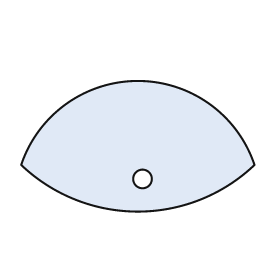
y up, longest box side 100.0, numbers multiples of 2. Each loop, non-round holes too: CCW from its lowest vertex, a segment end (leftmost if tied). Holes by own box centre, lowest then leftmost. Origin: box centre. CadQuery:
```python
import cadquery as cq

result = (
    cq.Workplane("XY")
    .moveTo(-50.0, -8.0)
    .threePointArc((0.0, -28.0), (50.0, -8.0))
    .threePointArc((0.0, 28.0), (-50.0, -8.0))
    .close()
    .moveTo(2.0, -14.0)
    .circle(4.0)
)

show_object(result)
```